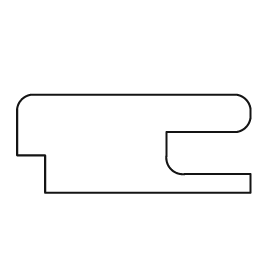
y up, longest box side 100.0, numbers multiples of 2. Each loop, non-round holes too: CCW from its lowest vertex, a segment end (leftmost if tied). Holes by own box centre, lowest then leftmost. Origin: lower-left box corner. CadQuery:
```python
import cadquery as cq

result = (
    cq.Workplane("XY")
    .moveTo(12.0, 0.0)
    .lineTo(100.0, 0.0)
    .lineTo(100.0, 8.0)
    .lineTo(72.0, 8.0)
    .threePointArc((66.0, 10.0), (64.0, 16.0))
    .lineTo(64.0, 26.0)
    .lineTo(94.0, 26.0)
    .threePointArc((98.0, 28.0), (100.0, 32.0))
    .lineTo(100.0, 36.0)
    .threePointArc((98.0, 40.0), (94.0, 42.0))
    .lineTo(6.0, 42.0)
    .threePointArc((2.0, 40.0), (0.0, 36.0))
    .lineTo(0.0, 16.0)
    .lineTo(12.0, 16.0)
    .close()
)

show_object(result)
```